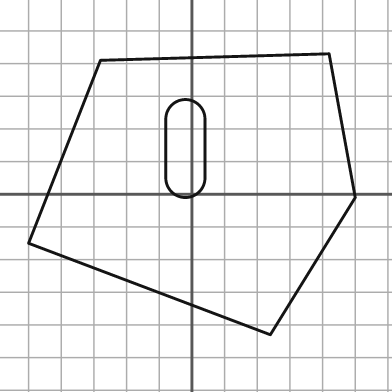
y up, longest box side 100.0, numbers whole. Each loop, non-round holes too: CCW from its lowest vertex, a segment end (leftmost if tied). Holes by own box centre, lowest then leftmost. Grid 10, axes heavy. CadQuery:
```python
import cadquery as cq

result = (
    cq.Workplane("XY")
    .moveTo(24.0, -43.0)
    .lineTo(50.0, -1.0)
    .lineTo(42.0, 43.0)
    .lineTo(-28.0, 41.0)
    .lineTo(-50.0, -15.0)
    .close()
    .moveTo(-8.0, 5.0)
    .threePointArc((-2.0, -1.0), (4.0, 5.0))
    .lineTo(4.0, 23.0)
    .threePointArc((-2.0, 29.0), (-8.0, 23.0))
    .close()
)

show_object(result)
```